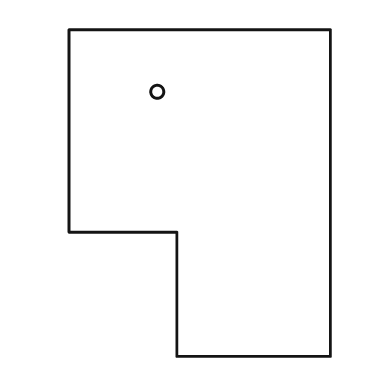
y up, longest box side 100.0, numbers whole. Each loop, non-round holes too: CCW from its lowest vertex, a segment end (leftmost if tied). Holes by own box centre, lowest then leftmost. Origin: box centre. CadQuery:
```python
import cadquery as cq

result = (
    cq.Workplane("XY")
    .moveTo(-7.0, -50.0)
    .lineTo(40.0, -50.0)
    .lineTo(40.0, 50.0)
    .lineTo(-40.0, 50.0)
    .lineTo(-40.0, -12.0)
    .lineTo(-7.0, -12.0)
    .close()
    .moveTo(-13.0, 31.0)
    .circle(2.0)
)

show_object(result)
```